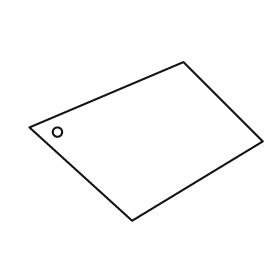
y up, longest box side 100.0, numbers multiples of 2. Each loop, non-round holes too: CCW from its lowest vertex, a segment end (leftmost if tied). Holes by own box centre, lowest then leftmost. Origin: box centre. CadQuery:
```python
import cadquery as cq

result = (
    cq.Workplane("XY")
    .moveTo(-6.0, -34.0)
    .lineTo(50.0, 0.0)
    .lineTo(16.0, 34.0)
    .lineTo(-50.0, 6.0)
    .close()
    .moveTo(-38.0, 4.0)
    .circle(2.0)
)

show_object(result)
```